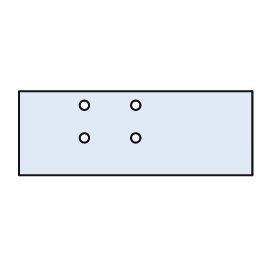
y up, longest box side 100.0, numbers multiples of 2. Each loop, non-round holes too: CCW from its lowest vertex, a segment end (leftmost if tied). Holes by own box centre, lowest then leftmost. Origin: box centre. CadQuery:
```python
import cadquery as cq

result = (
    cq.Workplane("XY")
    .moveTo(-50.0, -18.0)
    .lineTo(50.0, -18.0)
    .lineTo(50.0, 18.0)
    .lineTo(-50.0, 18.0)
    .close()
    .moveTo(-22.0, -2.0)
    .circle(2.0)
    .moveTo(0.0, -2.0)
    .circle(2.0)
    .moveTo(-22.0, 12.0)
    .circle(2.0)
    .moveTo(0.0, 12.0)
    .circle(2.0)
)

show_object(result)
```